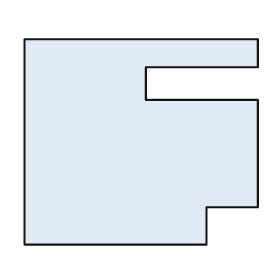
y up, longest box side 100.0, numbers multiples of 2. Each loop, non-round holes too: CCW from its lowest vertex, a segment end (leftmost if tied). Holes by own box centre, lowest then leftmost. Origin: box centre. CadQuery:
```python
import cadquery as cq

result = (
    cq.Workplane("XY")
    .moveTo(-50.0, -44.0)
    .lineTo(28.0, -44.0)
    .lineTo(28.0, -28.0)
    .lineTo(50.0, -28.0)
    .lineTo(50.0, 18.0)
    .lineTo(2.0, 18.0)
    .lineTo(2.0, 32.0)
    .lineTo(50.0, 32.0)
    .lineTo(50.0, 44.0)
    .lineTo(-50.0, 44.0)
    .close()
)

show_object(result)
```